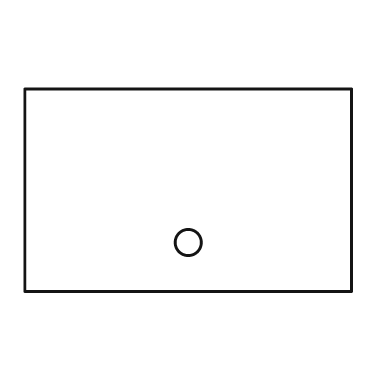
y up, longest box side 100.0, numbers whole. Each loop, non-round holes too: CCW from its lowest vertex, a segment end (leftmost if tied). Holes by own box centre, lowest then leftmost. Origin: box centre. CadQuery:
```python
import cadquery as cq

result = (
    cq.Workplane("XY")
    .moveTo(-50.0, -31.0)
    .lineTo(50.0, -31.0)
    .lineTo(50.0, 31.0)
    .lineTo(-50.0, 31.0)
    .close()
    .moveTo(0.0, -16.0)
    .circle(4.0)
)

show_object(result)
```